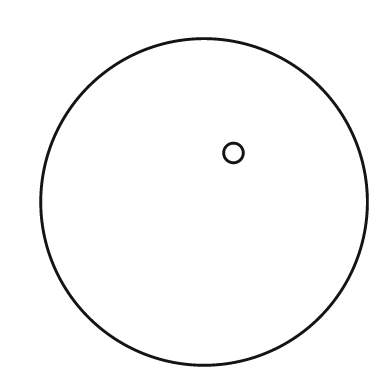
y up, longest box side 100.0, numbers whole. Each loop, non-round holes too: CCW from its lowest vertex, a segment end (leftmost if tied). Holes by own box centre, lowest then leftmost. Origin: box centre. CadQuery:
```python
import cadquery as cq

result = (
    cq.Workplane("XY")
    .moveTo(0.0, 0.0)
    .circle(50.0)
    .moveTo(9.0, 15.0)
    .circle(3.0)
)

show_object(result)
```